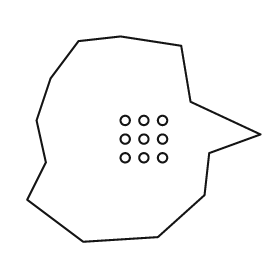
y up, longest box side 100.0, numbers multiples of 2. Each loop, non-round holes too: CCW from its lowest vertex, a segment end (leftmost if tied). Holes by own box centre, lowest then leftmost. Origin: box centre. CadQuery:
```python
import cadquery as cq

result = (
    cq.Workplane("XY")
    .moveTo(-26.0, -44.0)
    .lineTo(6.0, -42.0)
    .lineTo(26.0, -24.0)
    .lineTo(28.0, -6.0)
    .lineTo(50.0, 2.0)
    .lineTo(20.0, 16.0)
    .lineTo(16.0, 40.0)
    .lineTo(-10.0, 44.0)
    .lineTo(-28.0, 42.0)
    .lineTo(-40.0, 26.0)
    .lineTo(-46.0, 8.0)
    .lineTo(-42.0, -10.0)
    .lineTo(-50.0, -26.0)
    .close()
    .moveTo(-8.0, -8.0)
    .circle(2.0)
    .moveTo(0.0, -8.0)
    .circle(2.0)
    .moveTo(8.0, -8.0)
    .circle(2.0)
    .moveTo(-8.0, 0.0)
    .circle(2.0)
    .moveTo(0.0, 0.0)
    .circle(2.0)
    .moveTo(8.0, 0.0)
    .circle(2.0)
    .moveTo(-8.0, 8.0)
    .circle(2.0)
    .moveTo(0.0, 8.0)
    .circle(2.0)
    .moveTo(8.0, 8.0)
    .circle(2.0)
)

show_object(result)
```